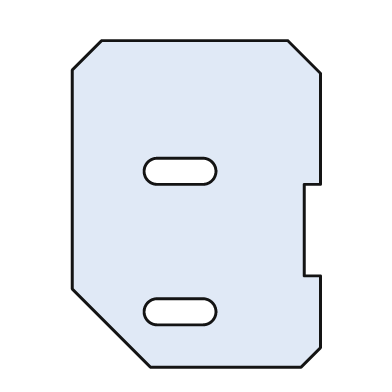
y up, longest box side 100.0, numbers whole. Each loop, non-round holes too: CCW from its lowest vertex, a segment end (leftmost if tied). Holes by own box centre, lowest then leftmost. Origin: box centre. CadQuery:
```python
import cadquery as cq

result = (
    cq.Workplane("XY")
    .moveTo(-14.0, -50.0)
    .lineTo(32.0, -50.0)
    .lineTo(38.0, -44.0)
    .lineTo(38.0, -22.0)
    .lineTo(33.0, -22.0)
    .lineTo(33.0, 6.0)
    .lineTo(38.0, 6.0)
    .lineTo(38.0, 40.0)
    .lineTo(28.0, 50.0)
    .lineTo(-29.0, 50.0)
    .lineTo(-38.0, 41.0)
    .lineTo(-38.0, -26.0)
    .close()
    .moveTo(-12.0, -37.0)
    .lineTo(2.0, -37.0)
    .threePointArc((6.0, -33.0), (2.0, -29.0))
    .lineTo(-12.0, -29.0)
    .threePointArc((-16.0, -33.0), (-12.0, -37.0))
    .close()
    .moveTo(-12.0, 6.0)
    .lineTo(2.0, 6.0)
    .threePointArc((6.0, 10.0), (2.0, 14.0))
    .lineTo(-12.0, 14.0)
    .threePointArc((-16.0, 10.0), (-12.0, 6.0))
    .close()
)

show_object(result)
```